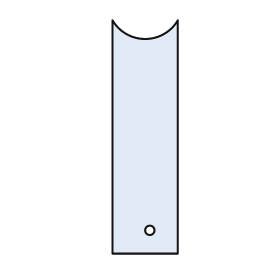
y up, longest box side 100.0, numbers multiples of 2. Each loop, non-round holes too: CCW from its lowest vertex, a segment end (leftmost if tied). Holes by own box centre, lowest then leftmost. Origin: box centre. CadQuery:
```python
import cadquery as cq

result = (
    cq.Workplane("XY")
    .moveTo(-14.0, -50.0)
    .lineTo(14.0, -50.0)
    .lineTo(14.0, 50.0)
    .threePointArc((0.0, 42.0), (-14.0, 50.0))
    .close()
    .moveTo(2.0, -40.0)
    .circle(2.0)
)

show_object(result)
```